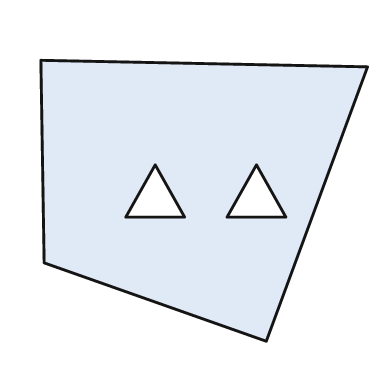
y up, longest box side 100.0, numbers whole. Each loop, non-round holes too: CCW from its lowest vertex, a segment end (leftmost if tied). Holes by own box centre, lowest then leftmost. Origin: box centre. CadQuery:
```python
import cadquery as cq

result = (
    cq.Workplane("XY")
    .moveTo(19.0, -43.0)
    .lineTo(50.0, 41.0)
    .lineTo(-50.0, 43.0)
    .lineTo(-49.0, -19.0)
    .close()
    .moveTo(-24.0, -5.0)
    .lineTo(-6.0, -5.0)
    .lineTo(-15.0, 11.0)
    .close()
    .moveTo(7.0, -5.0)
    .lineTo(25.0, -5.0)
    .lineTo(16.0, 11.0)
    .close()
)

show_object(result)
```